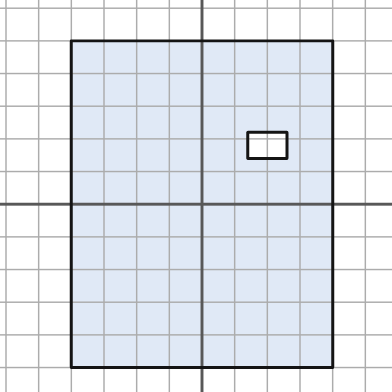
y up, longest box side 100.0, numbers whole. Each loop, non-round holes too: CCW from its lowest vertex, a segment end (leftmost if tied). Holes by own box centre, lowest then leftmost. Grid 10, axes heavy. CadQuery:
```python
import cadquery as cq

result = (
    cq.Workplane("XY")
    .moveTo(-40.0, -50.0)
    .lineTo(40.0, -50.0)
    .lineTo(40.0, 50.0)
    .lineTo(-40.0, 50.0)
    .close()
    .moveTo(14.0, 14.0)
    .lineTo(26.0, 14.0)
    .lineTo(26.0, 22.0)
    .lineTo(14.0, 22.0)
    .close()
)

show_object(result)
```